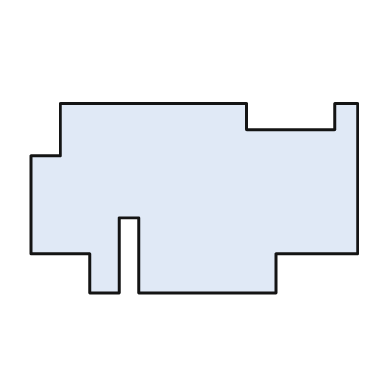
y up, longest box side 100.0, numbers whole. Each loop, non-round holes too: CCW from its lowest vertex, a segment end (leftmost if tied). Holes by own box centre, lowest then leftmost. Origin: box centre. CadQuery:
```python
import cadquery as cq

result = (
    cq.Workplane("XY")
    .moveTo(-32.0, -29.0)
    .lineTo(-23.0, -29.0)
    .lineTo(-23.0, -6.0)
    .lineTo(-17.0, -6.0)
    .lineTo(-17.0, -29.0)
    .lineTo(25.0, -29.0)
    .lineTo(25.0, -17.0)
    .lineTo(50.0, -17.0)
    .lineTo(50.0, 29.0)
    .lineTo(43.0, 29.0)
    .lineTo(43.0, 21.0)
    .lineTo(16.0, 21.0)
    .lineTo(16.0, 29.0)
    .lineTo(-41.0, 29.0)
    .lineTo(-41.0, 13.0)
    .lineTo(-50.0, 13.0)
    .lineTo(-50.0, -17.0)
    .lineTo(-32.0, -17.0)
    .close()
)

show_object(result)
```